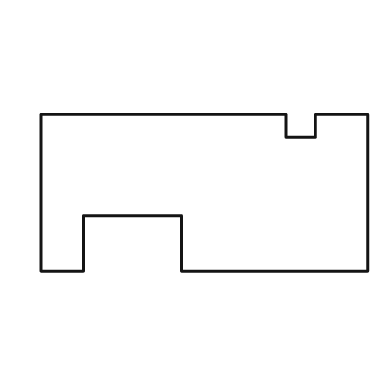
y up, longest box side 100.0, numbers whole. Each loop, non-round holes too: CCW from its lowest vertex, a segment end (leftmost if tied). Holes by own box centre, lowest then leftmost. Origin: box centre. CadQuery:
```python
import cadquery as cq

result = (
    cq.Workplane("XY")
    .moveTo(-50.0, -24.0)
    .lineTo(-37.0, -24.0)
    .lineTo(-37.0, -7.0)
    .lineTo(-7.0, -7.0)
    .lineTo(-7.0, -24.0)
    .lineTo(50.0, -24.0)
    .lineTo(50.0, 24.0)
    .lineTo(34.0, 24.0)
    .lineTo(34.0, 17.0)
    .lineTo(25.0, 17.0)
    .lineTo(25.0, 24.0)
    .lineTo(-50.0, 24.0)
    .close()
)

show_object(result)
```